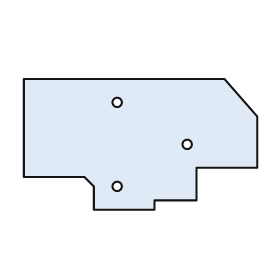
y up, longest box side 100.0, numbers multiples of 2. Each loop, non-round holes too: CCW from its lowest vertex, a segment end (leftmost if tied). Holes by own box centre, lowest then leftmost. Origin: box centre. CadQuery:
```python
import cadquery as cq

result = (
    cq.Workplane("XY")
    .moveTo(-20.0, -28.0)
    .lineTo(6.0, -28.0)
    .lineTo(6.0, -24.0)
    .lineTo(24.0, -24.0)
    .lineTo(24.0, -10.0)
    .lineTo(50.0, -10.0)
    .lineTo(50.0, 12.0)
    .lineTo(36.0, 28.0)
    .lineTo(-50.0, 28.0)
    .lineTo(-50.0, -14.0)
    .lineTo(-24.0, -14.0)
    .lineTo(-20.0, -18.0)
    .close()
    .moveTo(-10.0, -18.0)
    .circle(2.0)
    .moveTo(20.0, 0.0)
    .circle(2.0)
    .moveTo(-10.0, 18.0)
    .circle(2.0)
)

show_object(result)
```